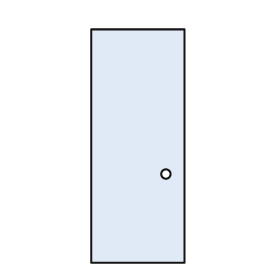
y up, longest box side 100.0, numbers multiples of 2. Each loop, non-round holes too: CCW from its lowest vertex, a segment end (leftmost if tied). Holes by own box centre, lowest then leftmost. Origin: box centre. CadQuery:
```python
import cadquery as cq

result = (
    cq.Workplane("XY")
    .moveTo(-20.0, -50.0)
    .lineTo(20.0, -50.0)
    .lineTo(20.0, 50.0)
    .lineTo(-20.0, 50.0)
    .close()
    .moveTo(12.0, -12.0)
    .circle(2.0)
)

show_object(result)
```